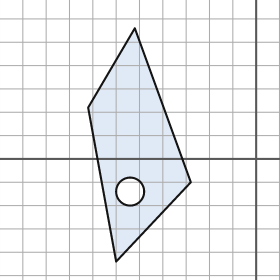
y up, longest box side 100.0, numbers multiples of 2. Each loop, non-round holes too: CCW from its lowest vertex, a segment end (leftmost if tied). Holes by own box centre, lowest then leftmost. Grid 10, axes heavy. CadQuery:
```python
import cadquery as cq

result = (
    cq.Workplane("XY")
    .moveTo(-60.0, -44.0)
    .lineTo(-28.0, -10.0)
    .lineTo(-52.0, 56.0)
    .lineTo(-72.0, 22.0)
    .close()
    .moveTo(-54.0, -14.0)
    .circle(6.0)
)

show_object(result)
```